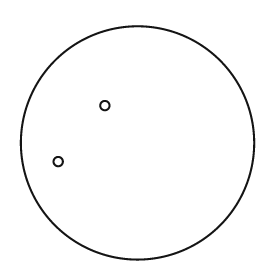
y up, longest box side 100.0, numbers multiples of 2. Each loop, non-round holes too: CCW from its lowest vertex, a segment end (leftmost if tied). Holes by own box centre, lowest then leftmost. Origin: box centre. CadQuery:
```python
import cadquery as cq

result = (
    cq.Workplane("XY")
    .moveTo(0.0, 0.0)
    .circle(50.0)
    .moveTo(-34.0, -8.0)
    .circle(2.0)
    .moveTo(-14.0, 16.0)
    .circle(2.0)
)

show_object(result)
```